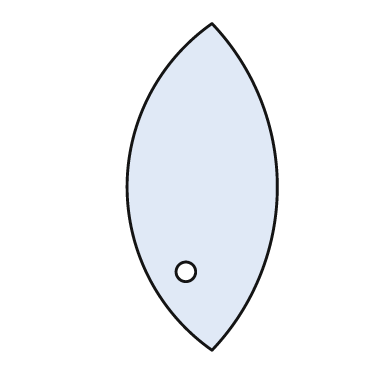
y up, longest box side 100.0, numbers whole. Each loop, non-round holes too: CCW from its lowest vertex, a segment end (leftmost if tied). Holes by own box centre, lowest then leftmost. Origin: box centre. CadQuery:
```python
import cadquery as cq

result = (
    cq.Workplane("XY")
    .moveTo(3.0, -50.0)
    .threePointArc((23.0, 0.0), (3.0, 50.0))
    .threePointArc((-23.0, 0.0), (3.0, -50.0))
    .close()
    .moveTo(-5.0, -26.0)
    .circle(3.0)
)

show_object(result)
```